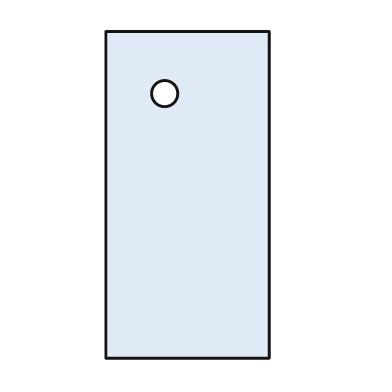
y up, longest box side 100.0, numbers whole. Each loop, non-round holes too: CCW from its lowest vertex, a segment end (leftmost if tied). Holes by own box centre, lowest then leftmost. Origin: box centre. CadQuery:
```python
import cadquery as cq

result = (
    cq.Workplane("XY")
    .moveTo(-25.0, -50.0)
    .lineTo(25.0, -50.0)
    .lineTo(25.0, 50.0)
    .lineTo(-25.0, 50.0)
    .close()
    .moveTo(-7.0, 31.0)
    .circle(4.0)
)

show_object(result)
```